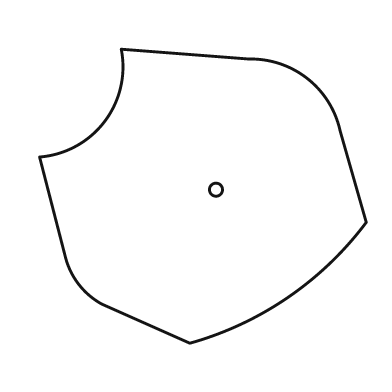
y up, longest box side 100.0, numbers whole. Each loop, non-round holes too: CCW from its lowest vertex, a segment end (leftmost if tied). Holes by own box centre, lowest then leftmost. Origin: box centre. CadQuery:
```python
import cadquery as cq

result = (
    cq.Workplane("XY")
    .moveTo(-4.0, -45.0)
    .threePointArc((26.0, -31.0), (50.0, -8.0))
    .lineTo(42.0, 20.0)
    .threePointArc((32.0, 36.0), (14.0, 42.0))
    .lineTo(-25.0, 45.0)
    .threePointArc((-30.0, 23.0), (-50.0, 12.0))
    .lineTo(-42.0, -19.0)
    .threePointArc((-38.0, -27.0), (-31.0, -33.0))
    .close()
    .moveTo(4.0, 2.0)
    .circle(2.0)
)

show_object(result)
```